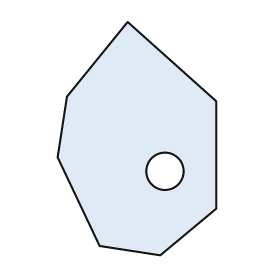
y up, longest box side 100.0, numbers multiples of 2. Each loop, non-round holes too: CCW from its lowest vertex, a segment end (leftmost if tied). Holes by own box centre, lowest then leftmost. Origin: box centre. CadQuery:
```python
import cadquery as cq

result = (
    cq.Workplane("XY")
    .moveTo(10.0, -50.0)
    .lineTo(34.0, -30.0)
    .lineTo(34.0, 16.0)
    .lineTo(-4.0, 50.0)
    .lineTo(-30.0, 18.0)
    .lineTo(-34.0, -8.0)
    .lineTo(-16.0, -46.0)
    .close()
    .moveTo(12.0, -14.0)
    .circle(8.0)
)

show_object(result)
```